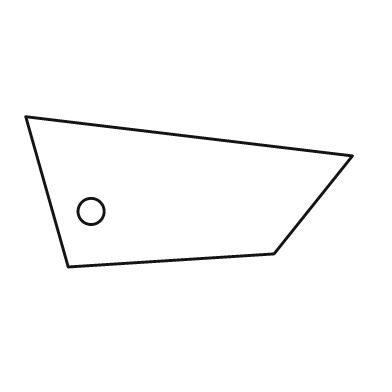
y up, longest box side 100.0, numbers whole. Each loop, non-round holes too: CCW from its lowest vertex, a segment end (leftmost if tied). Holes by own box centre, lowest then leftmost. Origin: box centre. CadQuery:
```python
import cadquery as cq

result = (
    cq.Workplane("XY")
    .moveTo(-37.0, -23.0)
    .lineTo(26.0, -19.0)
    .lineTo(50.0, 11.0)
    .lineTo(-50.0, 23.0)
    .close()
    .moveTo(-30.0, -6.0)
    .circle(4.0)
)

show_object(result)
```